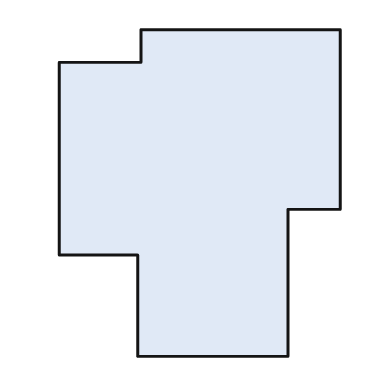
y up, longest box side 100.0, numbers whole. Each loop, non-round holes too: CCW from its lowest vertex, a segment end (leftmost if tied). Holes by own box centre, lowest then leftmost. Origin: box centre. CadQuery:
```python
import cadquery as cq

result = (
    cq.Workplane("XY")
    .moveTo(-19.0, -50.0)
    .lineTo(27.0, -50.0)
    .lineTo(27.0, -5.0)
    .lineTo(43.0, -5.0)
    .lineTo(43.0, 50.0)
    .lineTo(-18.0, 50.0)
    .lineTo(-18.0, 40.0)
    .lineTo(-43.0, 40.0)
    .lineTo(-43.0, -19.0)
    .lineTo(-19.0, -19.0)
    .close()
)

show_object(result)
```